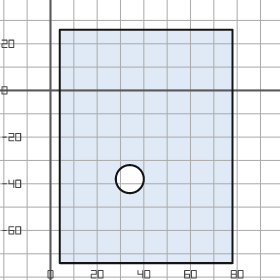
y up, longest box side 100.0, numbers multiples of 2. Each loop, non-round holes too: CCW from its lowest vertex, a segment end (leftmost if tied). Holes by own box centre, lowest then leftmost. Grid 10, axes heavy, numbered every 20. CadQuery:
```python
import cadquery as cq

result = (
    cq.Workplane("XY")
    .moveTo(4.0, -74.0)
    .lineTo(78.0, -74.0)
    .lineTo(78.0, 26.0)
    .lineTo(4.0, 26.0)
    .close()
    .moveTo(34.0, -38.0)
    .circle(6.0)
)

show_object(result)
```